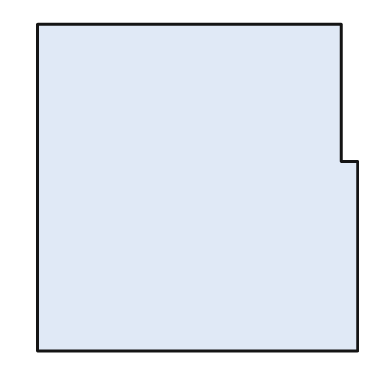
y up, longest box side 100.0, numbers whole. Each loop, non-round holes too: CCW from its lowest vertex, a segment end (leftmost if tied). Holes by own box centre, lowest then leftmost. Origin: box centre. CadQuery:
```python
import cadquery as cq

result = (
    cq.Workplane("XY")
    .moveTo(-49.0, -50.0)
    .lineTo(49.0, -50.0)
    .lineTo(49.0, 8.0)
    .lineTo(44.0, 8.0)
    .lineTo(44.0, 50.0)
    .lineTo(-49.0, 50.0)
    .close()
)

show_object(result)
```